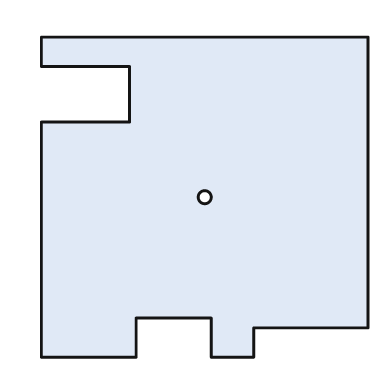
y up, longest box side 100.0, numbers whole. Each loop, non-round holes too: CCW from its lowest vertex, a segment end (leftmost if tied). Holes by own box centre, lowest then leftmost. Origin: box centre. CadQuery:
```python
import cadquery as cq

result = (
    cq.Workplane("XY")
    .moveTo(-50.0, -49.0)
    .lineTo(-21.0, -49.0)
    .lineTo(-21.0, -37.0)
    .lineTo(2.0, -37.0)
    .lineTo(2.0, -49.0)
    .lineTo(15.0, -49.0)
    .lineTo(15.0, -40.0)
    .lineTo(50.0, -40.0)
    .lineTo(50.0, 49.0)
    .lineTo(-50.0, 49.0)
    .lineTo(-50.0, 40.0)
    .lineTo(-23.0, 40.0)
    .lineTo(-23.0, 23.0)
    .lineTo(-50.0, 23.0)
    .close()
    .moveTo(0.0, 0.0)
    .circle(2.0)
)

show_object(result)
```